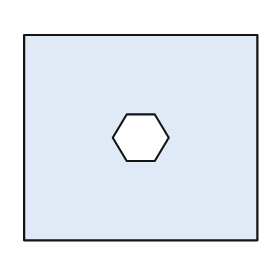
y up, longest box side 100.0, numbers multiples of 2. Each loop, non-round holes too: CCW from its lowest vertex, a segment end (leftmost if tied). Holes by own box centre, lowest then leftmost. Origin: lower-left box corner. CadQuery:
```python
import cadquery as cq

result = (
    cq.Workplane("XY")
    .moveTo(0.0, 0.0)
    .lineTo(100.0, 0.0)
    .lineTo(100.0, 88.0)
    .lineTo(0.0, 88.0)
    .close()
    .moveTo(44.0, 34.0)
    .lineTo(56.0, 34.0)
    .lineTo(62.0, 44.0)
    .lineTo(56.0, 54.0)
    .lineTo(44.0, 54.0)
    .lineTo(38.0, 44.0)
    .close()
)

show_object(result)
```